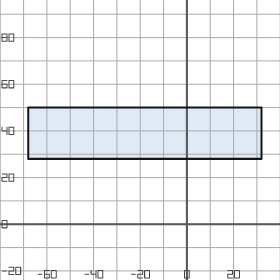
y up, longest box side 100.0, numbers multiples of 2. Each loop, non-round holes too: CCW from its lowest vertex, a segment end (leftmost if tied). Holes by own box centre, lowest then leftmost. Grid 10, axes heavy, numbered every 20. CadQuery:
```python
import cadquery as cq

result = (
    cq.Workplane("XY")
    .moveTo(-68.0, 28.0)
    .lineTo(32.0, 28.0)
    .lineTo(32.0, 50.0)
    .lineTo(-68.0, 50.0)
    .close()
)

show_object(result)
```